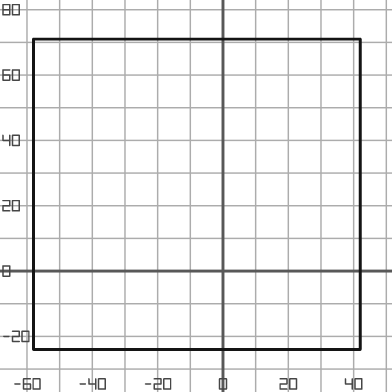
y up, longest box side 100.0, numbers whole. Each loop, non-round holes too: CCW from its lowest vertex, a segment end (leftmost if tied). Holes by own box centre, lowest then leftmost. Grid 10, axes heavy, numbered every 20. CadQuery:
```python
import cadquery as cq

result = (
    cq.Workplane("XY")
    .moveTo(-58.0, -24.0)
    .lineTo(42.0, -24.0)
    .lineTo(42.0, 71.0)
    .lineTo(-58.0, 71.0)
    .close()
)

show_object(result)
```